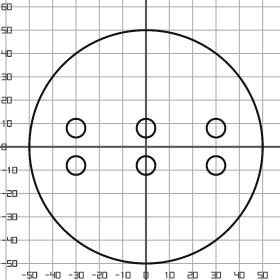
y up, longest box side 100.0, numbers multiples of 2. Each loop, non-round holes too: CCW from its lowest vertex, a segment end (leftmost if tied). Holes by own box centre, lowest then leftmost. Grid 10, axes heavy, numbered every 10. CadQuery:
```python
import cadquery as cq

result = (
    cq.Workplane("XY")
    .moveTo(0.0, 0.0)
    .circle(50.0)
    .moveTo(-30.0, -8.0)
    .circle(4.0)
    .moveTo(0.0, -8.0)
    .circle(4.0)
    .moveTo(30.0, -8.0)
    .circle(4.0)
    .moveTo(-30.0, 8.0)
    .circle(4.0)
    .moveTo(0.0, 8.0)
    .circle(4.0)
    .moveTo(30.0, 8.0)
    .circle(4.0)
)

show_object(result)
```